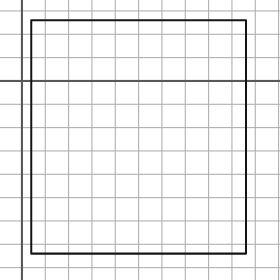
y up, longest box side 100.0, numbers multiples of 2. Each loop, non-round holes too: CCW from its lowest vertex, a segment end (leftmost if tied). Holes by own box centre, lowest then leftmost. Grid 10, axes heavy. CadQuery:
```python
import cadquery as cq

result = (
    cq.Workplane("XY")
    .moveTo(4.0, -74.0)
    .lineTo(96.0, -74.0)
    .lineTo(96.0, 26.0)
    .lineTo(4.0, 26.0)
    .close()
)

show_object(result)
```